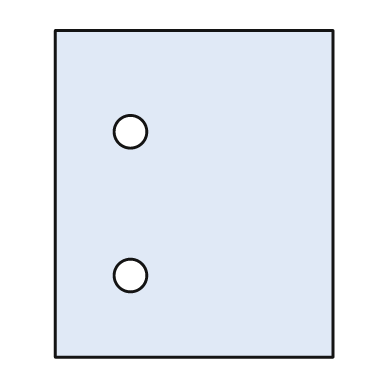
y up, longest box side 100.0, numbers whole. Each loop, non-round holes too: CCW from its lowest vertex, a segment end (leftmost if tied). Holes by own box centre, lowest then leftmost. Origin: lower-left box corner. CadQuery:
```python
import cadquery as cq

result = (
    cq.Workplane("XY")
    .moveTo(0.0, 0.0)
    .lineTo(85.0, 0.0)
    .lineTo(85.0, 100.0)
    .lineTo(0.0, 100.0)
    .close()
    .moveTo(23.0, 25.0)
    .circle(5.0)
    .moveTo(23.0, 69.0)
    .circle(5.0)
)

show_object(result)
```